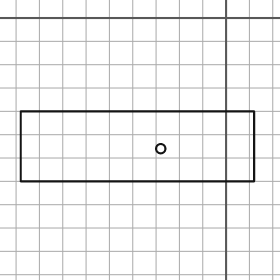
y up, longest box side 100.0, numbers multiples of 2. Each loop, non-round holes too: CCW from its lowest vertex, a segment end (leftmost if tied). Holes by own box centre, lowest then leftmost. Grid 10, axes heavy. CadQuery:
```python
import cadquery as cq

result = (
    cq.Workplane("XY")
    .moveTo(-88.0, -70.0)
    .lineTo(12.0, -70.0)
    .lineTo(12.0, -40.0)
    .lineTo(-88.0, -40.0)
    .close()
    .moveTo(-28.0, -56.0)
    .circle(2.0)
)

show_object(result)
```